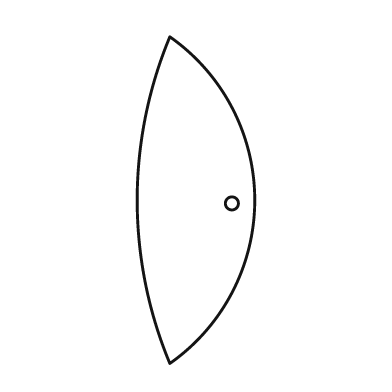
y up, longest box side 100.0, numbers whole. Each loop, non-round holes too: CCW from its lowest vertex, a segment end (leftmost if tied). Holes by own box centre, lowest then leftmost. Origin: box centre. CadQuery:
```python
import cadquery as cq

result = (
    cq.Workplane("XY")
    .moveTo(-8.0, -50.0)
    .threePointArc((18.0, 0.0), (-8.0, 50.0))
    .threePointArc((-18.0, 0.0), (-8.0, -50.0))
    .close()
    .moveTo(11.0, -1.0)
    .circle(2.0)
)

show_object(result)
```